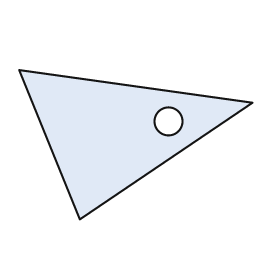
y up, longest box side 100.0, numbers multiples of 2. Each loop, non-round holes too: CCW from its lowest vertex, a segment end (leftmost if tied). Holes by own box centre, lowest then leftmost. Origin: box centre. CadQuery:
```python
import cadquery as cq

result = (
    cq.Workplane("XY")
    .moveTo(-24.0, -32.0)
    .lineTo(50.0, 18.0)
    .lineTo(-50.0, 32.0)
    .close()
    .moveTo(14.0, 10.0)
    .circle(6.0)
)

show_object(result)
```